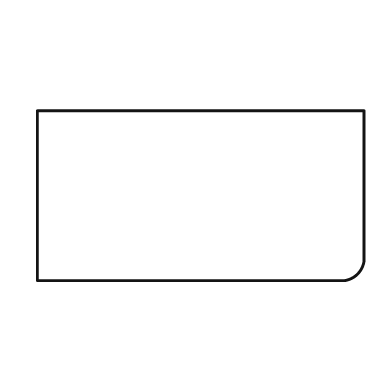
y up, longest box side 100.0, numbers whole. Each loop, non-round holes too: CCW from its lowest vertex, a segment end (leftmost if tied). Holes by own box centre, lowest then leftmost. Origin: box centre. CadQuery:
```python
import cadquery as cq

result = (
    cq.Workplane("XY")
    .moveTo(-50.0, -26.0)
    .lineTo(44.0, -26.0)
    .threePointArc((48.0, -24.0), (50.0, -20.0))
    .lineTo(50.0, 26.0)
    .lineTo(-50.0, 26.0)
    .close()
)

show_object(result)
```